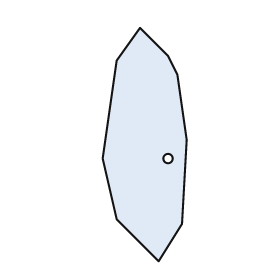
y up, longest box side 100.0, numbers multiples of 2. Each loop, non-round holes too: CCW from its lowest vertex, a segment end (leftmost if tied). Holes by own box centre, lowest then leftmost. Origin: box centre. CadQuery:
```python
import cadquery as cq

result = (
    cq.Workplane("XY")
    .moveTo(6.0, -50.0)
    .lineTo(16.0, -34.0)
    .lineTo(18.0, 2.0)
    .lineTo(14.0, 30.0)
    .lineTo(10.0, 38.0)
    .lineTo(-2.0, 50.0)
    .lineTo(-12.0, 36.0)
    .lineTo(-18.0, -6.0)
    .lineTo(-12.0, -32.0)
    .close()
    .moveTo(10.0, -6.0)
    .circle(2.0)
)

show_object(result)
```